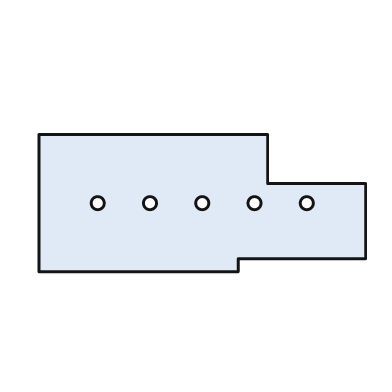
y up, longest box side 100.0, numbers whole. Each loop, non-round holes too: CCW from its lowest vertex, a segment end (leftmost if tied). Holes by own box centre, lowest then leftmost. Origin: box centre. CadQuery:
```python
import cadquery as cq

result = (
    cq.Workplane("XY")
    .moveTo(-50.0, -21.0)
    .lineTo(11.0, -21.0)
    .lineTo(11.0, -17.0)
    .lineTo(50.0, -17.0)
    .lineTo(50.0, 6.0)
    .lineTo(20.0, 6.0)
    .lineTo(20.0, 21.0)
    .lineTo(-50.0, 21.0)
    .close()
    .moveTo(-32.0, 0.0)
    .circle(2.0)
    .moveTo(-16.0, 0.0)
    .circle(2.0)
    .moveTo(0.0, 0.0)
    .circle(2.0)
    .moveTo(16.0, 0.0)
    .circle(2.0)
    .moveTo(32.0, 0.0)
    .circle(2.0)
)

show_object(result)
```